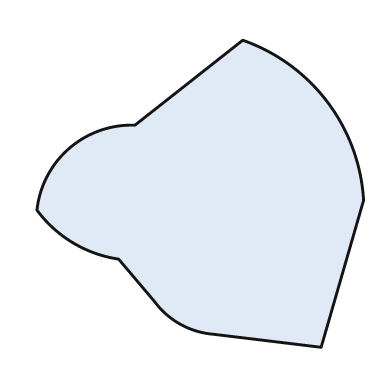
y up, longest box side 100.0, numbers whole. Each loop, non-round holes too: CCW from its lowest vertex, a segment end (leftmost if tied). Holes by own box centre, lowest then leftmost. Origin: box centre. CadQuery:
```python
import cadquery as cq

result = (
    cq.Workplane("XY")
    .moveTo(37.0, -47.0)
    .lineTo(50.0, -2.0)
    .threePointArc((39.0, 28.0), (13.0, 47.0))
    .lineTo(-20.0, 21.0)
    .threePointArc((-40.0, 14.0), (-50.0, -5.0))
    .threePointArc((-39.0, -15.0), (-25.0, -20.0))
    .lineTo(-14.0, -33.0)
    .threePointArc((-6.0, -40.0), (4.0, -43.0))
    .close()
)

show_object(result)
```